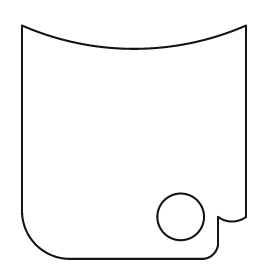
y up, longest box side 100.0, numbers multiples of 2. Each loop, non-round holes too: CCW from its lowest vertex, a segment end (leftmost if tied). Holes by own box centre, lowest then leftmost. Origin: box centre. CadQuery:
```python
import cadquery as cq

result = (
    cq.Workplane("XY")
    .moveTo(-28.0, -50.0)
    .lineTo(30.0, -50.0)
    .threePointArc((34.0, -48.0), (36.0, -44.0))
    .lineTo(36.0, -32.0)
    .threePointArc((42.0, -34.0), (48.0, -32.0))
    .lineTo(48.0, 50.0)
    .threePointArc((0.0, 40.0), (-48.0, 50.0))
    .lineTo(-48.0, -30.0)
    .threePointArc((-42.0, -44.0), (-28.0, -50.0))
    .close()
    .moveTo(20.0, -32.0)
    .circle(10.0)
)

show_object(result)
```